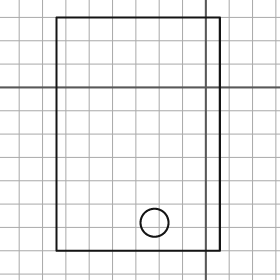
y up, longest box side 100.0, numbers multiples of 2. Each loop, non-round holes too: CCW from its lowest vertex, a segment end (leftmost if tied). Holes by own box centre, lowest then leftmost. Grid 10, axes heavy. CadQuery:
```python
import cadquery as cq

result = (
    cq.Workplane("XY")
    .moveTo(-64.0, -70.0)
    .lineTo(6.0, -70.0)
    .lineTo(6.0, 30.0)
    .lineTo(-64.0, 30.0)
    .close()
    .moveTo(-22.0, -58.0)
    .circle(6.0)
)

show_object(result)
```